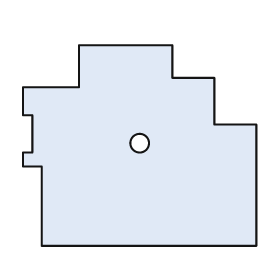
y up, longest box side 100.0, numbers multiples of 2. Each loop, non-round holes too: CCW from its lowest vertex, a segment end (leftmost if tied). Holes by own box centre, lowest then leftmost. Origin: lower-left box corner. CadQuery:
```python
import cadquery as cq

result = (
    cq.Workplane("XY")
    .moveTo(8.0, 0.0)
    .lineTo(100.0, 0.0)
    .lineTo(100.0, 52.0)
    .lineTo(82.0, 52.0)
    .lineTo(82.0, 72.0)
    .lineTo(64.0, 72.0)
    .lineTo(64.0, 86.0)
    .lineTo(24.0, 86.0)
    .lineTo(24.0, 68.0)
    .lineTo(0.0, 68.0)
    .lineTo(0.0, 56.0)
    .lineTo(4.0, 56.0)
    .lineTo(4.0, 40.0)
    .lineTo(0.0, 40.0)
    .lineTo(0.0, 34.0)
    .lineTo(8.0, 34.0)
    .close()
    .moveTo(50.0, 44.0)
    .circle(4.0)
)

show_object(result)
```